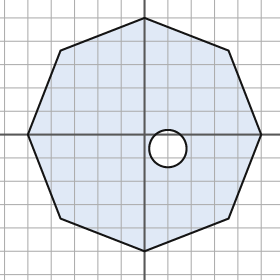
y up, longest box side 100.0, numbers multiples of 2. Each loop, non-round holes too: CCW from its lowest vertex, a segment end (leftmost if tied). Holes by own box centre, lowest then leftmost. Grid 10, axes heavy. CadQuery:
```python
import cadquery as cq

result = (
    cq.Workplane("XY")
    .moveTo(0.0, -50.0)
    .lineTo(36.0, -36.0)
    .lineTo(50.0, 0.0)
    .lineTo(36.0, 36.0)
    .lineTo(0.0, 50.0)
    .lineTo(-36.0, 36.0)
    .lineTo(-50.0, 0.0)
    .lineTo(-36.0, -36.0)
    .close()
    .moveTo(10.0, -6.0)
    .circle(8.0)
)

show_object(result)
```